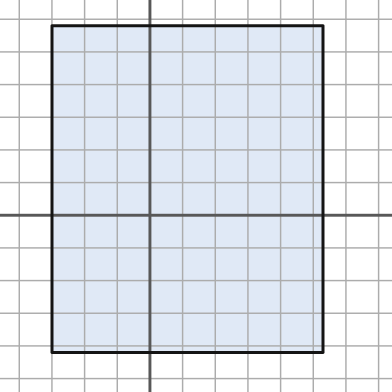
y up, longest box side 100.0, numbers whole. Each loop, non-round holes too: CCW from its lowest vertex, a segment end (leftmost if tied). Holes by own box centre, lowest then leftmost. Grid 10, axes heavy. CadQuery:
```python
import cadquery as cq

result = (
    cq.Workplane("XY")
    .moveTo(-30.0, -42.0)
    .lineTo(53.0, -42.0)
    .lineTo(53.0, 58.0)
    .lineTo(-30.0, 58.0)
    .close()
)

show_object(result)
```